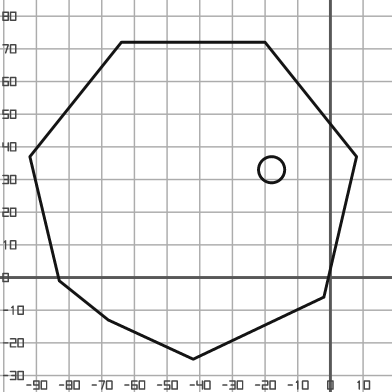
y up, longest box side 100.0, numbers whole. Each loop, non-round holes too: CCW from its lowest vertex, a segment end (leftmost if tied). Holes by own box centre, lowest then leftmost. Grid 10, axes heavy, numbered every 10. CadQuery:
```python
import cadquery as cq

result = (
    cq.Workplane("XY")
    .moveTo(-42.0, -25.0)
    .lineTo(-2.0, -6.0)
    .lineTo(8.0, 37.0)
    .lineTo(-20.0, 72.0)
    .lineTo(-64.0, 72.0)
    .lineTo(-92.0, 37.0)
    .lineTo(-83.0, -1.0)
    .lineTo(-68.0, -13.0)
    .close()
    .moveTo(-18.0, 33.0)
    .circle(4.0)
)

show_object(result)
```